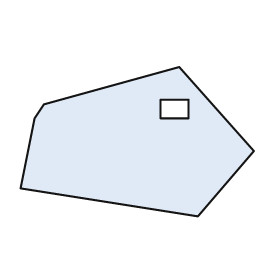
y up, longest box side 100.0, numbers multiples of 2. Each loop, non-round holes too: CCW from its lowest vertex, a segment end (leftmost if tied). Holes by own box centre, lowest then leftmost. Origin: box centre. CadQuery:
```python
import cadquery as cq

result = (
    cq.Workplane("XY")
    .moveTo(26.0, -32.0)
    .lineTo(50.0, -4.0)
    .lineTo(18.0, 32.0)
    .lineTo(-40.0, 16.0)
    .lineTo(-44.0, 10.0)
    .lineTo(-50.0, -20.0)
    .close()
    .moveTo(10.0, 10.0)
    .lineTo(22.0, 10.0)
    .lineTo(22.0, 18.0)
    .lineTo(10.0, 18.0)
    .close()
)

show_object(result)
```